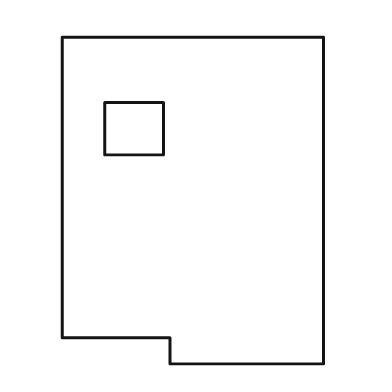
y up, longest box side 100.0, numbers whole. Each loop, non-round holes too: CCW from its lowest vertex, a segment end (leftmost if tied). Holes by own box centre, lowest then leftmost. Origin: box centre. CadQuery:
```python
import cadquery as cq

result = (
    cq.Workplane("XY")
    .moveTo(-7.0, -50.0)
    .lineTo(40.0, -50.0)
    .lineTo(40.0, 50.0)
    .lineTo(-40.0, 50.0)
    .lineTo(-40.0, -42.0)
    .lineTo(-7.0, -42.0)
    .close()
    .moveTo(-27.0, 14.0)
    .lineTo(-9.0, 14.0)
    .lineTo(-9.0, 30.0)
    .lineTo(-27.0, 30.0)
    .close()
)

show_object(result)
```